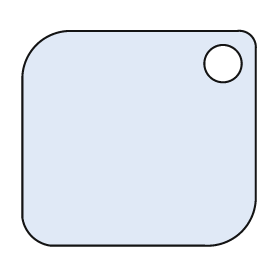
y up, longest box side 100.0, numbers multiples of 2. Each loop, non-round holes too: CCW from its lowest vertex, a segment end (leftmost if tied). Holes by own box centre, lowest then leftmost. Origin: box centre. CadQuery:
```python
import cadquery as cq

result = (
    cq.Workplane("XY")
    .moveTo(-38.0, -46.0)
    .lineTo(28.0, -46.0)
    .threePointArc((44.0, -40.0), (50.0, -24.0))
    .lineTo(50.0, 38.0)
    .threePointArc((48.0, 44.0), (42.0, 46.0))
    .lineTo(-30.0, 46.0)
    .threePointArc((-44.0, 40.0), (-50.0, 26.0))
    .lineTo(-50.0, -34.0)
    .threePointArc((-46.0, -42.0), (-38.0, -46.0))
    .close()
    .moveTo(36.0, 32.0)
    .circle(8.0)
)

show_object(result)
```